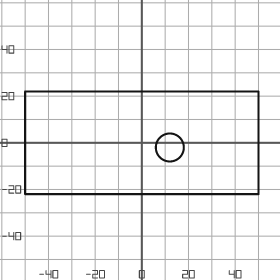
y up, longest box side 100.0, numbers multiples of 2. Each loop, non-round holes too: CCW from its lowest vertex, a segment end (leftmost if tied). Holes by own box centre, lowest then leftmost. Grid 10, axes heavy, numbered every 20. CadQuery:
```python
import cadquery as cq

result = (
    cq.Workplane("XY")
    .moveTo(-50.0, -22.0)
    .lineTo(50.0, -22.0)
    .lineTo(50.0, 22.0)
    .lineTo(-50.0, 22.0)
    .close()
    .moveTo(12.0, -2.0)
    .circle(6.0)
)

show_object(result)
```